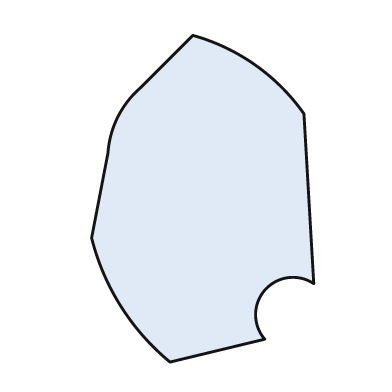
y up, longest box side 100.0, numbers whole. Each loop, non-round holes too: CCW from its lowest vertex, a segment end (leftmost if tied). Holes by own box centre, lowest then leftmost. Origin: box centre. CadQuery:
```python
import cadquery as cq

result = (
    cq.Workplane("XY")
    .moveTo(-10.0, -50.0)
    .lineTo(19.0, -43.0)
    .threePointArc((19.0, -28.0), (34.0, -26.0))
    .lineTo(31.0, 26.0)
    .threePointArc((16.0, 41.0), (-3.0, 50.0))
    .lineTo(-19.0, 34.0)
    .threePointArc((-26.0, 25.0), (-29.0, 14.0))
    .lineTo(-34.0, -12.0)
    .threePointArc((-25.0, -33.0), (-10.0, -50.0))
    .close()
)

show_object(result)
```